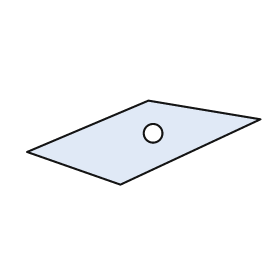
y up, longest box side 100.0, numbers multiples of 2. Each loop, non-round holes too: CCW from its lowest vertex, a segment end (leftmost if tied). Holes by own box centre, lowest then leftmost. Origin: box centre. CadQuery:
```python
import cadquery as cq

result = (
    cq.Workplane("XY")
    .moveTo(-10.0, -18.0)
    .lineTo(50.0, 10.0)
    .lineTo(2.0, 18.0)
    .lineTo(-50.0, -4.0)
    .close()
    .moveTo(4.0, 4.0)
    .circle(4.0)
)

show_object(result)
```